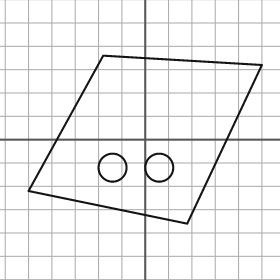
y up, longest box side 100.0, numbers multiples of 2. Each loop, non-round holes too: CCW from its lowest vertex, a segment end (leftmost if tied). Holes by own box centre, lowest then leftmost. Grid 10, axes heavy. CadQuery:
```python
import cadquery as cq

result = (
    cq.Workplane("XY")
    .moveTo(18.0, -36.0)
    .lineTo(50.0, 32.0)
    .lineTo(-18.0, 36.0)
    .lineTo(-50.0, -22.0)
    .close()
    .moveTo(-14.0, -12.0)
    .circle(6.0)
    .moveTo(6.0, -12.0)
    .circle(6.0)
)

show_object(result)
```